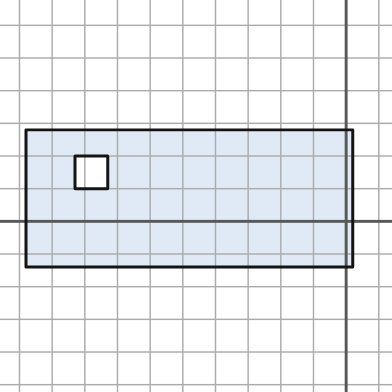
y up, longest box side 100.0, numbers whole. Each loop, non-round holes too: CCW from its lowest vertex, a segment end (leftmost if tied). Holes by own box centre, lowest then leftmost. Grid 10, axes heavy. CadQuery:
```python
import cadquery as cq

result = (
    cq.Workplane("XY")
    .moveTo(-98.0, -14.0)
    .lineTo(2.0, -14.0)
    .lineTo(2.0, 28.0)
    .lineTo(-98.0, 28.0)
    .close()
    .moveTo(-83.0, 10.0)
    .lineTo(-73.0, 10.0)
    .lineTo(-73.0, 20.0)
    .lineTo(-83.0, 20.0)
    .close()
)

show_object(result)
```